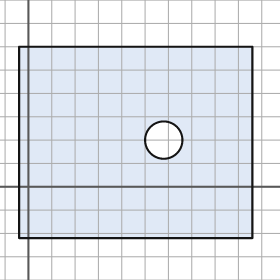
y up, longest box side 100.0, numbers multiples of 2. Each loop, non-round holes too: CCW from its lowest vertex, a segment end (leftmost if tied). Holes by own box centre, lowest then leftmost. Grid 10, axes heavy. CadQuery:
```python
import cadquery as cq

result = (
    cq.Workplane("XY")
    .moveTo(-4.0, -22.0)
    .lineTo(96.0, -22.0)
    .lineTo(96.0, 60.0)
    .lineTo(-4.0, 60.0)
    .close()
    .moveTo(58.0, 20.0)
    .circle(8.0)
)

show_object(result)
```